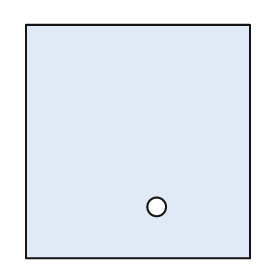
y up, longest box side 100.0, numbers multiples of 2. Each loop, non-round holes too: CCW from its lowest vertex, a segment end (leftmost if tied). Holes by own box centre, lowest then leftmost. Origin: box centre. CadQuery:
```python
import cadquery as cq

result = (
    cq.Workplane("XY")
    .moveTo(-48.0, -50.0)
    .lineTo(48.0, -50.0)
    .lineTo(48.0, 50.0)
    .lineTo(-48.0, 50.0)
    .close()
    .moveTo(8.0, -28.0)
    .circle(4.0)
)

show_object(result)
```